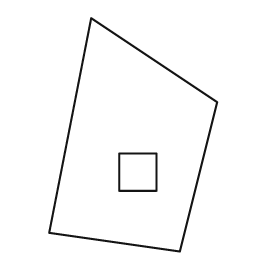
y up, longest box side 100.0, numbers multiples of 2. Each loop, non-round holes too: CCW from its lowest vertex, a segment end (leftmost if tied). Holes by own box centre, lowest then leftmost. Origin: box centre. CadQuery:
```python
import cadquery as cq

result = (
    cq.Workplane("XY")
    .moveTo(20.0, -50.0)
    .lineTo(36.0, 14.0)
    .lineTo(-18.0, 50.0)
    .lineTo(-36.0, -42.0)
    .close()
    .moveTo(-6.0, -24.0)
    .lineTo(10.0, -24.0)
    .lineTo(10.0, -8.0)
    .lineTo(-6.0, -8.0)
    .close()
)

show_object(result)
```